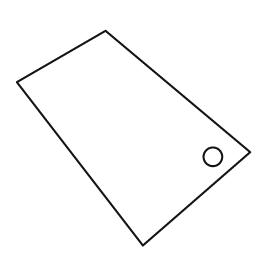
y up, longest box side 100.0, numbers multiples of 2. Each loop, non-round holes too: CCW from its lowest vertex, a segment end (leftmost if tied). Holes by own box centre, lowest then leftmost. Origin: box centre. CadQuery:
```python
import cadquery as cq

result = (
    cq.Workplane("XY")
    .moveTo(4.0, -46.0)
    .lineTo(50.0, -6.0)
    .lineTo(-12.0, 46.0)
    .lineTo(-50.0, 24.0)
    .close()
    .moveTo(34.0, -8.0)
    .circle(4.0)
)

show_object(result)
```